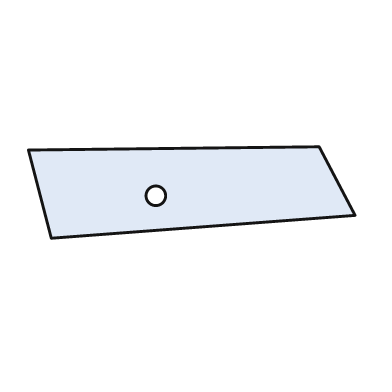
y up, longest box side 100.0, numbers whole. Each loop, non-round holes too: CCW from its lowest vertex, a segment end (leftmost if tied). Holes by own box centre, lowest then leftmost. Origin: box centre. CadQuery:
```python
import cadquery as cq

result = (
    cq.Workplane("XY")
    .moveTo(-43.0, -14.0)
    .lineTo(50.0, -7.0)
    .lineTo(39.0, 14.0)
    .lineTo(-50.0, 13.0)
    .close()
    .moveTo(-11.0, -1.0)
    .circle(3.0)
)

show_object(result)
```